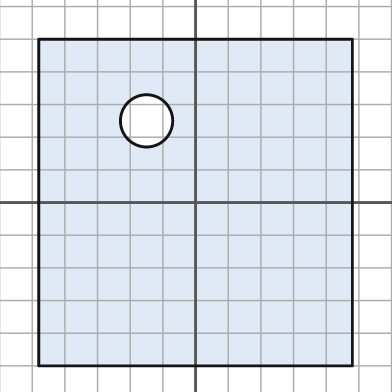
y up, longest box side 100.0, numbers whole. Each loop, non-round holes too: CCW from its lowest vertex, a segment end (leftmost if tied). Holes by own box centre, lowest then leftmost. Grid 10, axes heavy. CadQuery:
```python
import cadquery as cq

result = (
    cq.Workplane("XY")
    .moveTo(-48.0, -50.0)
    .lineTo(48.0, -50.0)
    .lineTo(48.0, 50.0)
    .lineTo(-48.0, 50.0)
    .close()
    .moveTo(-15.0, 25.0)
    .circle(8.0)
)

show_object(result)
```